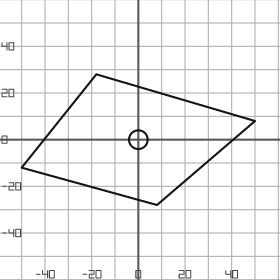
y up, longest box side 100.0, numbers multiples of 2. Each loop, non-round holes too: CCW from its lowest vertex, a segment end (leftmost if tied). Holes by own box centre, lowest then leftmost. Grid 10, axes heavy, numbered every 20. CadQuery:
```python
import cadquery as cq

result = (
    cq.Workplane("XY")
    .moveTo(8.0, -28.0)
    .lineTo(50.0, 8.0)
    .lineTo(-18.0, 28.0)
    .lineTo(-50.0, -12.0)
    .close()
    .moveTo(0.0, 0.0)
    .circle(4.0)
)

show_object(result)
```